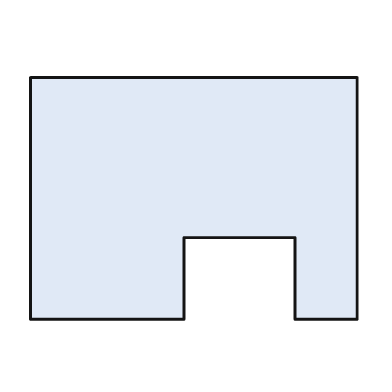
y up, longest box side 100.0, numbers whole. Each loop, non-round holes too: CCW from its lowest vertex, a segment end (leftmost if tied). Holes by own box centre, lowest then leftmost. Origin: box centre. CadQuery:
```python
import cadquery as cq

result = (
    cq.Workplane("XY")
    .moveTo(-50.0, -37.0)
    .lineTo(-3.0, -37.0)
    .lineTo(-3.0, -12.0)
    .lineTo(31.0, -12.0)
    .lineTo(31.0, -37.0)
    .lineTo(50.0, -37.0)
    .lineTo(50.0, 37.0)
    .lineTo(-50.0, 37.0)
    .close()
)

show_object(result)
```